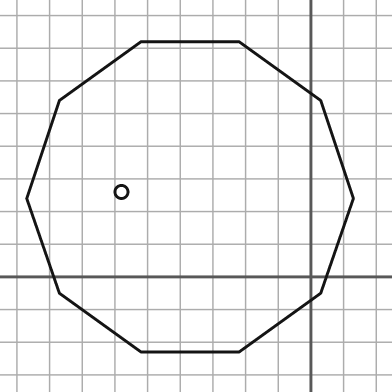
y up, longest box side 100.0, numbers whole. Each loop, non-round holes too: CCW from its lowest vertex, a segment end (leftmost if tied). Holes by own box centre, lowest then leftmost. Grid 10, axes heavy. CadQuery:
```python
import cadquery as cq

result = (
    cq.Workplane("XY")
    .moveTo(-52.0, -23.0)
    .lineTo(-22.0, -23.0)
    .lineTo(3.0, -5.0)
    .lineTo(13.0, 24.0)
    .lineTo(3.0, 54.0)
    .lineTo(-22.0, 72.0)
    .lineTo(-52.0, 72.0)
    .lineTo(-77.0, 54.0)
    .lineTo(-87.0, 24.0)
    .lineTo(-77.0, -5.0)
    .close()
    .moveTo(-58.0, 26.0)
    .circle(2.0)
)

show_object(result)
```